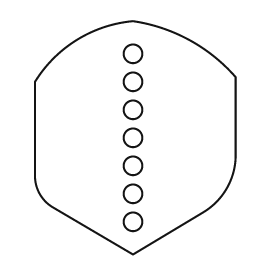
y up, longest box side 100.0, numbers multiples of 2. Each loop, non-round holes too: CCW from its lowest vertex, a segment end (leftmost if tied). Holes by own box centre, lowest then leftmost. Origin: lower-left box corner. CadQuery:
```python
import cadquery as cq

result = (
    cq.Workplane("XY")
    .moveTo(42.0, 0.0)
    .lineTo(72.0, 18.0)
    .threePointArc((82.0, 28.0), (86.0, 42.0))
    .lineTo(86.0, 76.0)
    .threePointArc((66.0, 92.0), (42.0, 100.0))
    .threePointArc((18.0, 92.0), (0.0, 74.0))
    .lineTo(0.0, 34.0)
    .threePointArc((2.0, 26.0), (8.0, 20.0))
    .close()
    .moveTo(42.0, 14.0)
    .circle(4.0)
    .moveTo(42.0, 26.0)
    .circle(4.0)
    .moveTo(42.0, 38.0)
    .circle(4.0)
    .moveTo(42.0, 50.0)
    .circle(4.0)
    .moveTo(42.0, 62.0)
    .circle(4.0)
    .moveTo(42.0, 74.0)
    .circle(4.0)
    .moveTo(42.0, 86.0)
    .circle(4.0)
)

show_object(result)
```